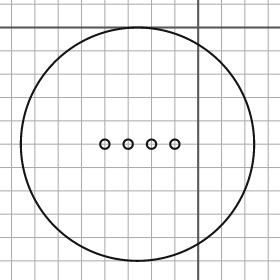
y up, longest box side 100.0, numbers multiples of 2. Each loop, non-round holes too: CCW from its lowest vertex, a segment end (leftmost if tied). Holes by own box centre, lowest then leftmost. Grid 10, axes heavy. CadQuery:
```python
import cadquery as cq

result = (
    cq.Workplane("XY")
    .moveTo(-26.0, -50.0)
    .circle(50.0)
    .moveTo(-40.0, -50.0)
    .circle(2.0)
    .moveTo(-30.0, -50.0)
    .circle(2.0)
    .moveTo(-20.0, -50.0)
    .circle(2.0)
    .moveTo(-10.0, -50.0)
    .circle(2.0)
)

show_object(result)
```